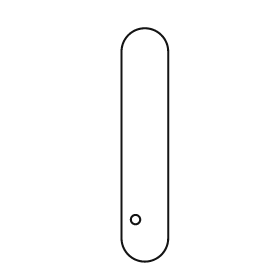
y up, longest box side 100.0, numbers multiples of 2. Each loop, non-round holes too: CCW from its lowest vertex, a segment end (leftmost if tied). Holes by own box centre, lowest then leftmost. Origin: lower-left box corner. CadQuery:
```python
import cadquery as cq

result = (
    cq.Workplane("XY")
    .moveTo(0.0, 10.0)
    .threePointArc((10.0, 0.0), (20.0, 10.0))
    .lineTo(20.0, 90.0)
    .threePointArc((10.0, 100.0), (0.0, 90.0))
    .close()
    .moveTo(6.0, 18.0)
    .circle(2.0)
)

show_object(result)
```